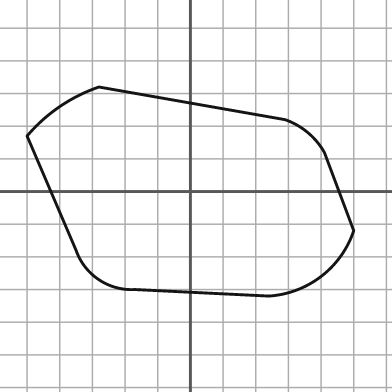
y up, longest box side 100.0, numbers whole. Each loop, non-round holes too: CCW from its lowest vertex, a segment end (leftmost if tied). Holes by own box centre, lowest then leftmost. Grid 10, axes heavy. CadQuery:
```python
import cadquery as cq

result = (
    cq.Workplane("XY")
    .moveTo(24.0, -32.0)
    .threePointArc((40.0, -26.0), (50.0, -12.0))
    .lineTo(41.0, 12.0)
    .threePointArc((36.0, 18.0), (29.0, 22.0))
    .lineTo(-28.0, 32.0)
    .threePointArc((-40.0, 26.0), (-50.0, 17.0))
    .lineTo(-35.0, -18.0)
    .threePointArc((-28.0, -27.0), (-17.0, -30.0))
    .close()
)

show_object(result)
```